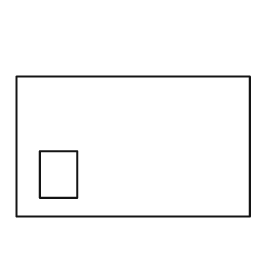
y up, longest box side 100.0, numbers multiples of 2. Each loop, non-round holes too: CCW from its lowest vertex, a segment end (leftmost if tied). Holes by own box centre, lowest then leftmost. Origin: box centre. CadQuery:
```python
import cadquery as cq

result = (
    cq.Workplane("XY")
    .moveTo(-50.0, -30.0)
    .lineTo(50.0, -30.0)
    .lineTo(50.0, 30.0)
    .lineTo(-50.0, 30.0)
    .close()
    .moveTo(-40.0, -22.0)
    .lineTo(-24.0, -22.0)
    .lineTo(-24.0, -2.0)
    .lineTo(-40.0, -2.0)
    .close()
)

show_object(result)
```